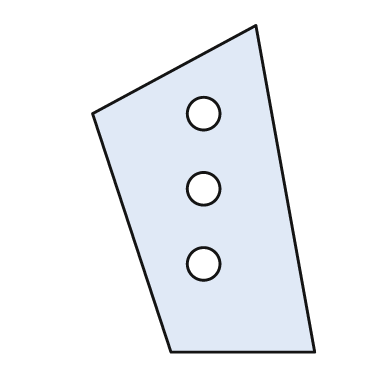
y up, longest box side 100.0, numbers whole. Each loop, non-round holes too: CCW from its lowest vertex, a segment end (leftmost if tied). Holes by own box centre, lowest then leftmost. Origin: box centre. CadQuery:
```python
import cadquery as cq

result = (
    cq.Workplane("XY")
    .moveTo(-10.0, -50.0)
    .lineTo(34.0, -50.0)
    .lineTo(16.0, 50.0)
    .lineTo(-34.0, 23.0)
    .close()
    .moveTo(0.0, -23.0)
    .circle(5.0)
    .moveTo(0.0, 0.0)
    .circle(5.0)
    .moveTo(0.0, 23.0)
    .circle(5.0)
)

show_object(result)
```